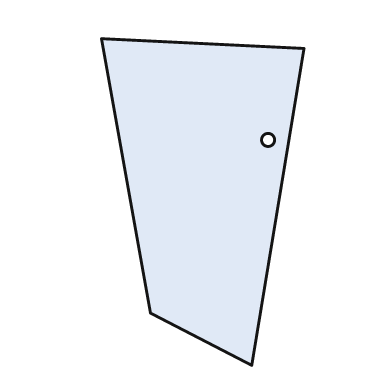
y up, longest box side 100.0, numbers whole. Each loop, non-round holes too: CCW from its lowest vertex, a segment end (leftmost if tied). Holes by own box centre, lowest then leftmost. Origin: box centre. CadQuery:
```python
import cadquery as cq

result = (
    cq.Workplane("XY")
    .moveTo(15.0, -50.0)
    .lineTo(31.0, 47.0)
    .lineTo(-31.0, 50.0)
    .lineTo(-16.0, -34.0)
    .close()
    .moveTo(20.0, 19.0)
    .circle(2.0)
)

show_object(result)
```